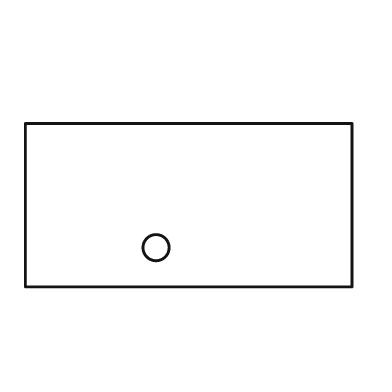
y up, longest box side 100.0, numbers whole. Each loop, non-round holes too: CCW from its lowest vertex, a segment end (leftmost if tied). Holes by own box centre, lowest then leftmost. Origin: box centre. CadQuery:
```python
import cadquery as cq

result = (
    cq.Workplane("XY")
    .moveTo(-50.0, -25.0)
    .lineTo(50.0, -25.0)
    .lineTo(50.0, 25.0)
    .lineTo(-50.0, 25.0)
    .close()
    .moveTo(-10.0, -13.0)
    .circle(4.0)
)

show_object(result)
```